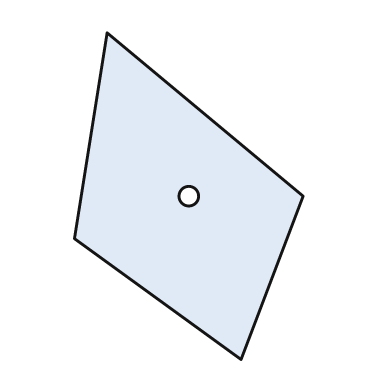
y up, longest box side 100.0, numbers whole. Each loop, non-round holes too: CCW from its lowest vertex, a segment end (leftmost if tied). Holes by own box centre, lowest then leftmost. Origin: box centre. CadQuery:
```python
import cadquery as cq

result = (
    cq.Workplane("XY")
    .moveTo(16.0, -50.0)
    .lineTo(35.0, 0.0)
    .lineTo(-25.0, 50.0)
    .lineTo(-35.0, -13.0)
    .close()
    .moveTo(0.0, 0.0)
    .circle(3.0)
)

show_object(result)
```